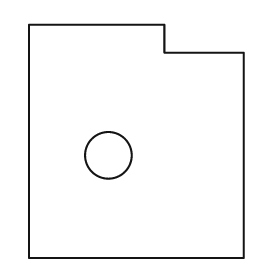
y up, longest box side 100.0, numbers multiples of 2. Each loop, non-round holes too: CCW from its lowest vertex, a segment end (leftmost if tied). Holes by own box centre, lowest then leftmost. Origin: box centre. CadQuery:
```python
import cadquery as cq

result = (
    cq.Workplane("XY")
    .moveTo(-46.0, -50.0)
    .lineTo(46.0, -50.0)
    .lineTo(46.0, 38.0)
    .lineTo(12.0, 38.0)
    .lineTo(12.0, 50.0)
    .lineTo(-46.0, 50.0)
    .close()
    .moveTo(-12.0, -6.0)
    .circle(10.0)
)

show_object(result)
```